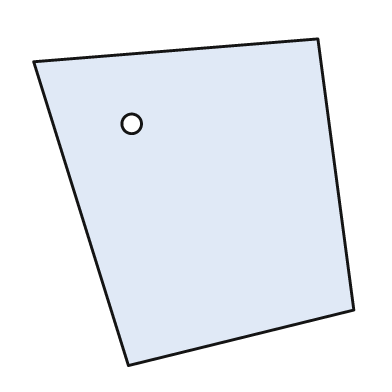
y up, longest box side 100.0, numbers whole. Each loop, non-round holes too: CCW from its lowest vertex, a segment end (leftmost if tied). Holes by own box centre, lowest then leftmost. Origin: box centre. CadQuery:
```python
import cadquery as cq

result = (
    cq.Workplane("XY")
    .moveTo(-20.0, -50.0)
    .lineTo(49.0, -33.0)
    .lineTo(38.0, 50.0)
    .lineTo(-49.0, 43.0)
    .close()
    .moveTo(-19.0, 24.0)
    .circle(3.0)
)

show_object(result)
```